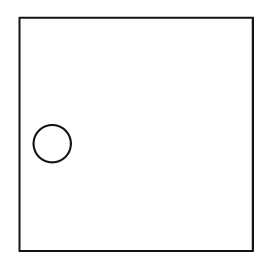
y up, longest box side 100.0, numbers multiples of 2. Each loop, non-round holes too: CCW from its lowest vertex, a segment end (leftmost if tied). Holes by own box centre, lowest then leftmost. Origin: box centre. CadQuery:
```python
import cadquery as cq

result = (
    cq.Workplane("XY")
    .moveTo(-50.0, -50.0)
    .lineTo(50.0, -50.0)
    .lineTo(50.0, 50.0)
    .lineTo(-50.0, 50.0)
    .close()
    .moveTo(-36.0, -4.0)
    .circle(8.0)
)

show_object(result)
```